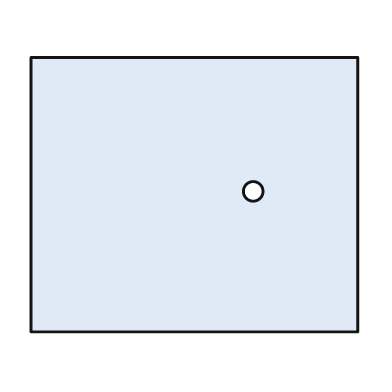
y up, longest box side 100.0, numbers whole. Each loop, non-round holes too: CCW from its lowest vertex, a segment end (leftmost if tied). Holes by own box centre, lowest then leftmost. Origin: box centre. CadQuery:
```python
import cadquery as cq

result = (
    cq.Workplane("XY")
    .moveTo(-50.0, -42.0)
    .lineTo(50.0, -42.0)
    .lineTo(50.0, 42.0)
    .lineTo(-50.0, 42.0)
    .close()
    .moveTo(18.0, 1.0)
    .circle(3.0)
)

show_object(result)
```